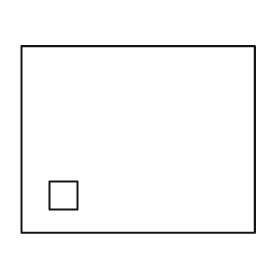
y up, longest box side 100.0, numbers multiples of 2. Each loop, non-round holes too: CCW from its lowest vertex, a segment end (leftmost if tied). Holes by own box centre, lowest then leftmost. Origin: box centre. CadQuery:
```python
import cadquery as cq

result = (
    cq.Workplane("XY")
    .moveTo(-50.0, -40.0)
    .lineTo(50.0, -40.0)
    .lineTo(50.0, 40.0)
    .lineTo(-50.0, 40.0)
    .close()
    .moveTo(-38.0, -30.0)
    .lineTo(-26.0, -30.0)
    .lineTo(-26.0, -18.0)
    .lineTo(-38.0, -18.0)
    .close()
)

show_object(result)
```